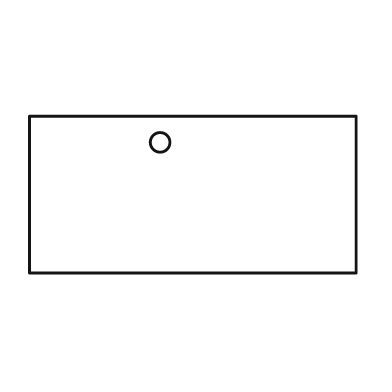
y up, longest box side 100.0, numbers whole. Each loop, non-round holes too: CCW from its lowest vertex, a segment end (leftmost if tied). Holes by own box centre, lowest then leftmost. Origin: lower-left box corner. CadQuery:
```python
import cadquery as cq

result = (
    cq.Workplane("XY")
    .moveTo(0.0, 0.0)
    .lineTo(100.0, 0.0)
    .lineTo(100.0, 48.0)
    .lineTo(0.0, 48.0)
    .close()
    .moveTo(40.0, 40.0)
    .circle(3.0)
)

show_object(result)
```